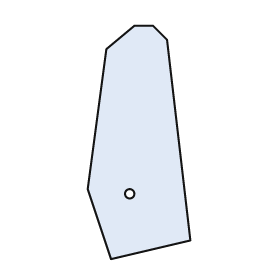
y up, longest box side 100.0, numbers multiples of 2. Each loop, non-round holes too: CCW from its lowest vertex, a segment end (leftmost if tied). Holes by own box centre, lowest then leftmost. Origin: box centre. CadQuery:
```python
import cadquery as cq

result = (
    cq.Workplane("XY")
    .moveTo(-12.0, -50.0)
    .lineTo(22.0, -42.0)
    .lineTo(12.0, 44.0)
    .lineTo(6.0, 50.0)
    .lineTo(-2.0, 50.0)
    .lineTo(-14.0, 40.0)
    .lineTo(-22.0, -20.0)
    .close()
    .moveTo(-4.0, -22.0)
    .circle(2.0)
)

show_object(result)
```